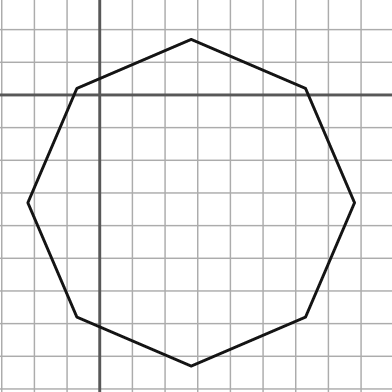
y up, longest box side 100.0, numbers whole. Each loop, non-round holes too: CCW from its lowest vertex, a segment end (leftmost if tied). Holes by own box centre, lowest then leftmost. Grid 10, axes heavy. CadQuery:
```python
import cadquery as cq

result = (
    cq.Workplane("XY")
    .moveTo(28.0, -83.0)
    .lineTo(63.0, -68.0)
    .lineTo(78.0, -33.0)
    .lineTo(63.0, 2.0)
    .lineTo(28.0, 17.0)
    .lineTo(-7.0, 2.0)
    .lineTo(-22.0, -33.0)
    .lineTo(-7.0, -68.0)
    .close()
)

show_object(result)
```